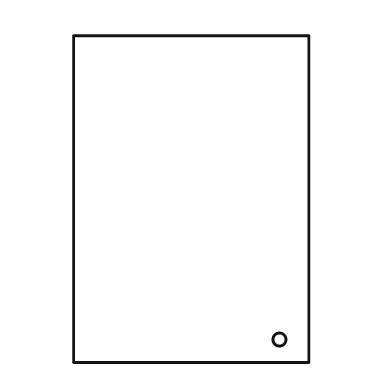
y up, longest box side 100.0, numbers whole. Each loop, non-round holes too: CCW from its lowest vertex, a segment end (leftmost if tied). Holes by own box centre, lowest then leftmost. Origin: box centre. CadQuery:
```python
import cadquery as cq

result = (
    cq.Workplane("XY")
    .moveTo(-36.0, -50.0)
    .lineTo(36.0, -50.0)
    .lineTo(36.0, 50.0)
    .lineTo(-36.0, 50.0)
    .close()
    .moveTo(27.0, -43.0)
    .circle(2.0)
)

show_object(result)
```